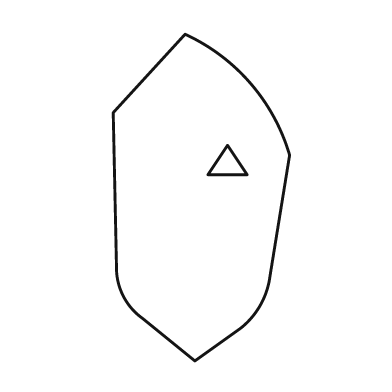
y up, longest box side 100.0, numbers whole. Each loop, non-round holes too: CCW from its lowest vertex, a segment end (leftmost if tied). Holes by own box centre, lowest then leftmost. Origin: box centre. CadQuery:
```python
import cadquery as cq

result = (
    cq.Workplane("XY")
    .moveTo(-2.0, -50.0)
    .lineTo(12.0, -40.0)
    .threePointArc((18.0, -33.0), (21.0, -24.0))
    .lineTo(27.0, 13.0)
    .threePointArc((15.0, 35.0), (-5.0, 50.0))
    .lineTo(-27.0, 26.0)
    .lineTo(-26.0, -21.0)
    .threePointArc((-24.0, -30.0), (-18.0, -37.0))
    .close()
    .moveTo(2.0, 7.0)
    .lineTo(14.0, 7.0)
    .lineTo(8.0, 16.0)
    .close()
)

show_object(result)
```